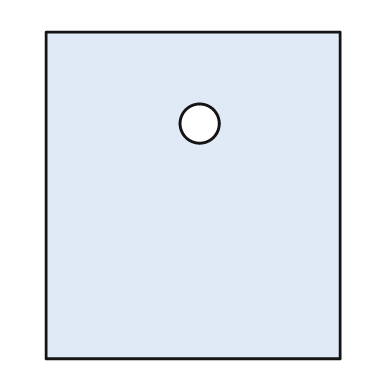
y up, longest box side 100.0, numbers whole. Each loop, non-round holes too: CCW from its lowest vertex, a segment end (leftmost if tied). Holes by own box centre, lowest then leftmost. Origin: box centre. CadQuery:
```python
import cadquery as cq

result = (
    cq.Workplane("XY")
    .moveTo(-45.0, -50.0)
    .lineTo(45.0, -50.0)
    .lineTo(45.0, 50.0)
    .lineTo(-45.0, 50.0)
    .close()
    .moveTo(2.0, 22.0)
    .circle(6.0)
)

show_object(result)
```